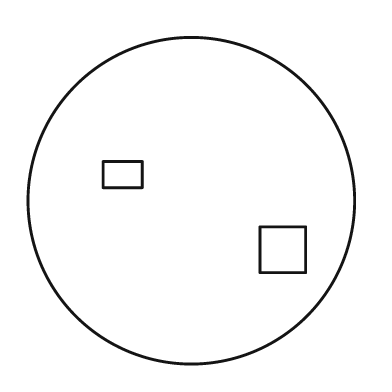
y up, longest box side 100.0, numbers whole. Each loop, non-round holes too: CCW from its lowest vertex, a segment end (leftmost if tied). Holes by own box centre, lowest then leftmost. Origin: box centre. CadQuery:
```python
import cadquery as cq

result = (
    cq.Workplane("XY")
    .moveTo(0.0, 0.0)
    .circle(50.0)
    .moveTo(21.0, -22.0)
    .lineTo(35.0, -22.0)
    .lineTo(35.0, -8.0)
    .lineTo(21.0, -8.0)
    .close()
    .moveTo(-27.0, 4.0)
    .lineTo(-15.0, 4.0)
    .lineTo(-15.0, 12.0)
    .lineTo(-27.0, 12.0)
    .close()
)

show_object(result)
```